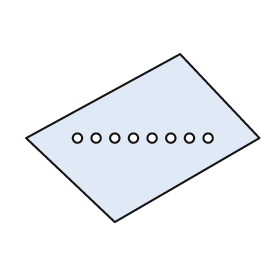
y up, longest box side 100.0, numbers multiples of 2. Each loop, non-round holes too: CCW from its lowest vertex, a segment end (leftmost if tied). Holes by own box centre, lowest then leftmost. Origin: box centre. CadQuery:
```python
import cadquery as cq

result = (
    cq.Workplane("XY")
    .moveTo(-12.0, -36.0)
    .lineTo(50.0, 0.0)
    .lineTo(16.0, 36.0)
    .lineTo(-50.0, 0.0)
    .close()
    .moveTo(-28.0, 0.0)
    .circle(2.0)
    .moveTo(-20.0, 0.0)
    .circle(2.0)
    .moveTo(-12.0, 0.0)
    .circle(2.0)
    .moveTo(-4.0, 0.0)
    .circle(2.0)
    .moveTo(4.0, 0.0)
    .circle(2.0)
    .moveTo(12.0, 0.0)
    .circle(2.0)
    .moveTo(20.0, 0.0)
    .circle(2.0)
    .moveTo(28.0, 0.0)
    .circle(2.0)
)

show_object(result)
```